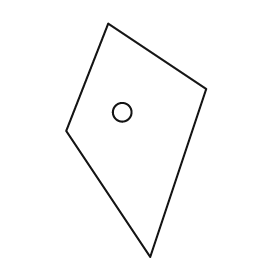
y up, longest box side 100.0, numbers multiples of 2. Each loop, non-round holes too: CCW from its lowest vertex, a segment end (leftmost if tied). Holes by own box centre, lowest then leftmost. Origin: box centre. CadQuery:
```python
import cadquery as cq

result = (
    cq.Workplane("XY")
    .moveTo(6.0, -50.0)
    .lineTo(30.0, 22.0)
    .lineTo(-12.0, 50.0)
    .lineTo(-30.0, 4.0)
    .close()
    .moveTo(-6.0, 12.0)
    .circle(4.0)
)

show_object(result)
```